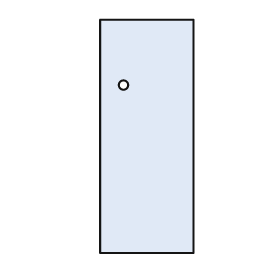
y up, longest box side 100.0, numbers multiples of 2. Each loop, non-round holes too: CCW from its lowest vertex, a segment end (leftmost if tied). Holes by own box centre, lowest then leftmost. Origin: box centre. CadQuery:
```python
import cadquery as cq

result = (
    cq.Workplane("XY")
    .moveTo(-20.0, -50.0)
    .lineTo(20.0, -50.0)
    .lineTo(20.0, 50.0)
    .lineTo(-20.0, 50.0)
    .close()
    .moveTo(-10.0, 22.0)
    .circle(2.0)
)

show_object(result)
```